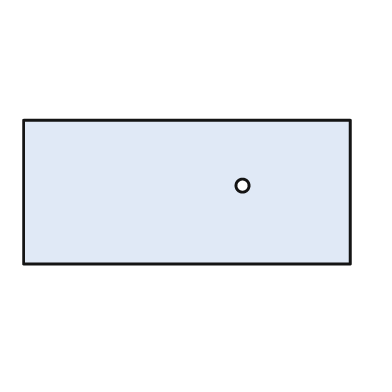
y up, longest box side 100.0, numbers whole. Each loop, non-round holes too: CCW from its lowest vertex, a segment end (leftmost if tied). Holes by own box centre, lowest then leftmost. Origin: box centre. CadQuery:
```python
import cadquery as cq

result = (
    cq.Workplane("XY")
    .moveTo(-50.0, -22.0)
    .lineTo(50.0, -22.0)
    .lineTo(50.0, 22.0)
    .lineTo(-50.0, 22.0)
    .close()
    .moveTo(17.0, 2.0)
    .circle(2.0)
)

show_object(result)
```